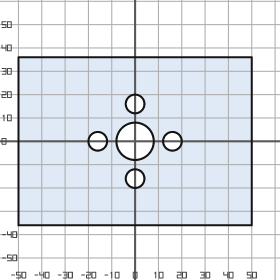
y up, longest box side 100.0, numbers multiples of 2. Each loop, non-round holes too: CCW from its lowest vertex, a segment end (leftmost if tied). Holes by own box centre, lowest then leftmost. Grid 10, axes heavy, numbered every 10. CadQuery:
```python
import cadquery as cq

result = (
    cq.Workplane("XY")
    .moveTo(-50.0, -36.0)
    .lineTo(50.0, -36.0)
    .lineTo(50.0, 36.0)
    .lineTo(-50.0, 36.0)
    .close()
    .moveTo(0.0, -16.0)
    .circle(4.0)
    .moveTo(-16.0, 0.0)
    .circle(4.0)
    .moveTo(0.0, 0.0)
    .circle(8.0)
    .moveTo(16.0, 0.0)
    .circle(4.0)
    .moveTo(0.0, 16.0)
    .circle(4.0)
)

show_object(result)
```